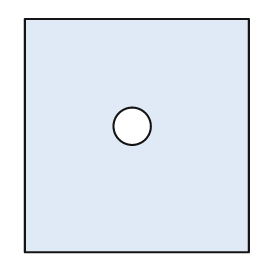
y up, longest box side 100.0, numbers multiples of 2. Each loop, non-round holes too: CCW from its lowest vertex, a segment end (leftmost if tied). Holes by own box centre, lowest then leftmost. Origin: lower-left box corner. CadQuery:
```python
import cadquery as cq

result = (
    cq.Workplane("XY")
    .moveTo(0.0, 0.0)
    .lineTo(96.0, 0.0)
    .lineTo(96.0, 100.0)
    .lineTo(0.0, 100.0)
    .close()
    .moveTo(46.0, 54.0)
    .circle(8.0)
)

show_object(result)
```